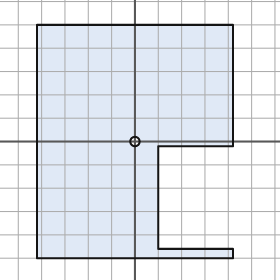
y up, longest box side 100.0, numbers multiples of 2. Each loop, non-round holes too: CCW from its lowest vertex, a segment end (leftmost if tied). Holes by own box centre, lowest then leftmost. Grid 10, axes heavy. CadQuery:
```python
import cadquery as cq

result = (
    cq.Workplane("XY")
    .moveTo(-42.0, -50.0)
    .lineTo(42.0, -50.0)
    .lineTo(42.0, -46.0)
    .lineTo(10.0, -46.0)
    .lineTo(10.0, -2.0)
    .lineTo(42.0, -2.0)
    .lineTo(42.0, 50.0)
    .lineTo(-42.0, 50.0)
    .close()
    .moveTo(0.0, 0.0)
    .circle(2.0)
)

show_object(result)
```